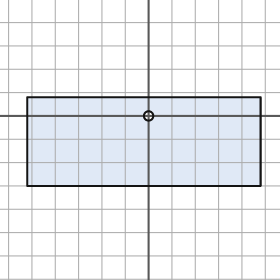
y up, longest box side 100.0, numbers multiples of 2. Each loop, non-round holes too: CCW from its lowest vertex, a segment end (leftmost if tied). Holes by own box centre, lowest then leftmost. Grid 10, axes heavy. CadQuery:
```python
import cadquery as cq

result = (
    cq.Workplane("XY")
    .moveTo(-52.0, -30.0)
    .lineTo(48.0, -30.0)
    .lineTo(48.0, 8.0)
    .lineTo(-52.0, 8.0)
    .close()
    .moveTo(0.0, 0.0)
    .circle(2.0)
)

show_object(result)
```